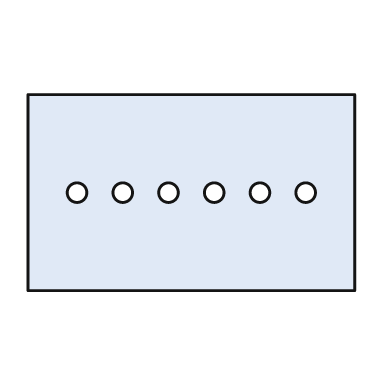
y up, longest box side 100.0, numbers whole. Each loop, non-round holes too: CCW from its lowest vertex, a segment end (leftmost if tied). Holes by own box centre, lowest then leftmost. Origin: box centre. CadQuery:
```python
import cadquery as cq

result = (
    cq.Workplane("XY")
    .moveTo(-50.0, -30.0)
    .lineTo(50.0, -30.0)
    .lineTo(50.0, 30.0)
    .lineTo(-50.0, 30.0)
    .close()
    .moveTo(-35.0, 0.0)
    .circle(3.0)
    .moveTo(-21.0, 0.0)
    .circle(3.0)
    .moveTo(-7.0, 0.0)
    .circle(3.0)
    .moveTo(7.0, 0.0)
    .circle(3.0)
    .moveTo(21.0, 0.0)
    .circle(3.0)
    .moveTo(35.0, 0.0)
    .circle(3.0)
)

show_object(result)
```